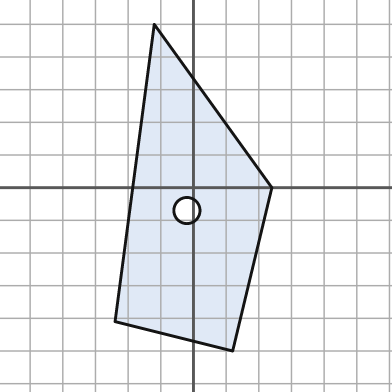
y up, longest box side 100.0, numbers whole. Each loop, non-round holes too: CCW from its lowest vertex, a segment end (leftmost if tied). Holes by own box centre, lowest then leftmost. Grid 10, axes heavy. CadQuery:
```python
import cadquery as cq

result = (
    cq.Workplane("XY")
    .moveTo(12.0, -50.0)
    .lineTo(24.0, 0.0)
    .lineTo(-12.0, 50.0)
    .lineTo(-24.0, -41.0)
    .close()
    .moveTo(-2.0, -7.0)
    .circle(4.0)
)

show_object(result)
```